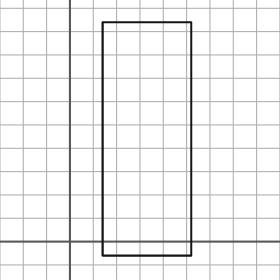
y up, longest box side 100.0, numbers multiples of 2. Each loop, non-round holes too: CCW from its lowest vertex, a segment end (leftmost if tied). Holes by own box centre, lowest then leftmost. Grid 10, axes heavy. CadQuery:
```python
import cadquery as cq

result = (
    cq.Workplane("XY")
    .moveTo(14.0, -6.0)
    .lineTo(52.0, -6.0)
    .lineTo(52.0, 94.0)
    .lineTo(14.0, 94.0)
    .close()
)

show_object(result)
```